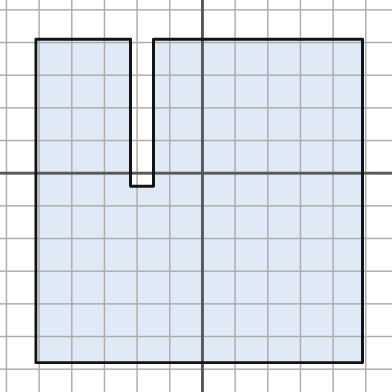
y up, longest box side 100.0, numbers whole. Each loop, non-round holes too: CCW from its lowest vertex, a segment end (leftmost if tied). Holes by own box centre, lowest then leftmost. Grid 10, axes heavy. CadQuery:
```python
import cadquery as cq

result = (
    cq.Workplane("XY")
    .moveTo(-51.0, -58.0)
    .lineTo(49.0, -58.0)
    .lineTo(49.0, 41.0)
    .lineTo(-15.0, 41.0)
    .lineTo(-15.0, -4.0)
    .lineTo(-22.0, -4.0)
    .lineTo(-22.0, 41.0)
    .lineTo(-51.0, 41.0)
    .close()
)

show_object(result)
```